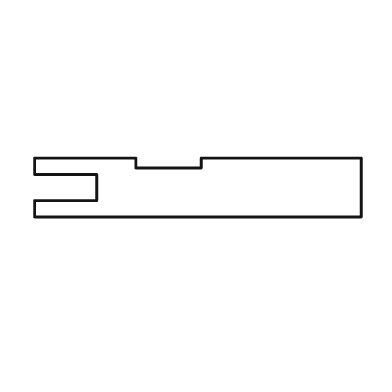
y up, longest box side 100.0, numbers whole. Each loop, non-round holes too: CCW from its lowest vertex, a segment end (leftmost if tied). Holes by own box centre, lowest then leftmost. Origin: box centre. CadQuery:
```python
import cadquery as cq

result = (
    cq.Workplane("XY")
    .moveTo(-50.0, -9.0)
    .lineTo(50.0, -9.0)
    .lineTo(50.0, 9.0)
    .lineTo(1.0, 9.0)
    .lineTo(1.0, 6.0)
    .lineTo(-19.0, 6.0)
    .lineTo(-19.0, 9.0)
    .lineTo(-50.0, 9.0)
    .lineTo(-50.0, 4.0)
    .lineTo(-31.0, 4.0)
    .lineTo(-31.0, -4.0)
    .lineTo(-50.0, -4.0)
    .close()
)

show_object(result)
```